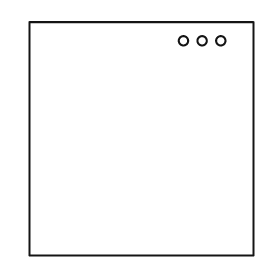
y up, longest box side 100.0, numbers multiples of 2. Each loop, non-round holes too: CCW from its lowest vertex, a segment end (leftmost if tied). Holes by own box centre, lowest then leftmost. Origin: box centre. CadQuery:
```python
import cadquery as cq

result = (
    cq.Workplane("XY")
    .moveTo(-48.0, -50.0)
    .lineTo(48.0, -50.0)
    .lineTo(48.0, 50.0)
    .lineTo(-48.0, 50.0)
    .close()
    .moveTo(18.0, 42.0)
    .circle(2.0)
    .moveTo(26.0, 42.0)
    .circle(2.0)
    .moveTo(34.0, 42.0)
    .circle(2.0)
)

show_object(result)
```